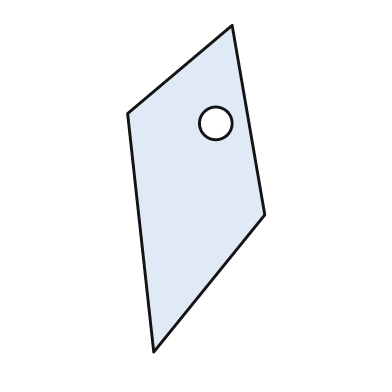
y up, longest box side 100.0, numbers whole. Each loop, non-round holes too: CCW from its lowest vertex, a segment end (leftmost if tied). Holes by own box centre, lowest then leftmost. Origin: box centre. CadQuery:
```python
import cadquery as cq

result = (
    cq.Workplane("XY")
    .moveTo(-13.0, -50.0)
    .lineTo(21.0, -8.0)
    .lineTo(11.0, 50.0)
    .lineTo(-21.0, 23.0)
    .close()
    .moveTo(6.0, 20.0)
    .circle(5.0)
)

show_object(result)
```